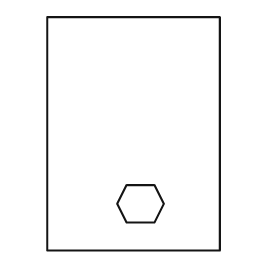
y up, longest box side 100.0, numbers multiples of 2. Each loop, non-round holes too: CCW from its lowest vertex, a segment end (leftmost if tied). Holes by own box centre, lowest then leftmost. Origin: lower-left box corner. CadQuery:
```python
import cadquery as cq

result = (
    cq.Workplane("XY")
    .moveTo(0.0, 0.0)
    .lineTo(74.0, 0.0)
    .lineTo(74.0, 100.0)
    .lineTo(0.0, 100.0)
    .close()
    .moveTo(34.0, 12.0)
    .lineTo(46.0, 12.0)
    .lineTo(50.0, 20.0)
    .lineTo(46.0, 28.0)
    .lineTo(34.0, 28.0)
    .lineTo(30.0, 20.0)
    .close()
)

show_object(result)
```